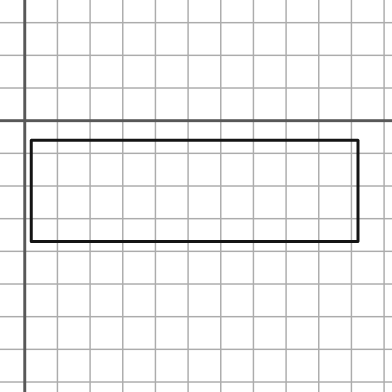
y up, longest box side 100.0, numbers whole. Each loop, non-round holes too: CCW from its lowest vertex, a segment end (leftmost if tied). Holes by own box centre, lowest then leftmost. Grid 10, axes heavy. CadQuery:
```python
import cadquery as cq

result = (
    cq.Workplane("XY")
    .moveTo(2.0, -37.0)
    .lineTo(102.0, -37.0)
    .lineTo(102.0, -6.0)
    .lineTo(2.0, -6.0)
    .close()
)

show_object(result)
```